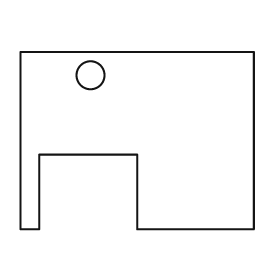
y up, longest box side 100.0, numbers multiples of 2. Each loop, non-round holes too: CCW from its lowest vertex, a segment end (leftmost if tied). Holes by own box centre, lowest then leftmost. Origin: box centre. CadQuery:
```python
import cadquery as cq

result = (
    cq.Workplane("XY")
    .moveTo(-50.0, -38.0)
    .lineTo(-42.0, -38.0)
    .lineTo(-42.0, -6.0)
    .lineTo(0.0, -6.0)
    .lineTo(0.0, -38.0)
    .lineTo(50.0, -38.0)
    .lineTo(50.0, 38.0)
    .lineTo(-50.0, 38.0)
    .close()
    .moveTo(-20.0, 28.0)
    .circle(6.0)
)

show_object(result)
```